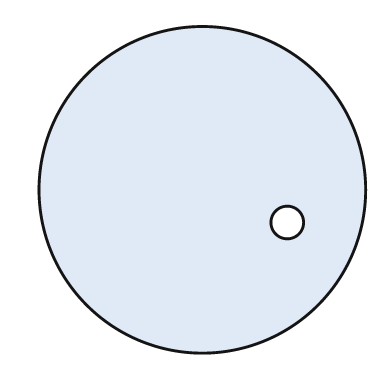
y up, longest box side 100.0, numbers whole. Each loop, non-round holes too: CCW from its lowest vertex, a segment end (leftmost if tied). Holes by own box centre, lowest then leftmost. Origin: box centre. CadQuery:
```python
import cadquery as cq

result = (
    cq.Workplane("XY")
    .moveTo(0.0, 0.0)
    .circle(50.0)
    .moveTo(26.0, -10.0)
    .circle(5.0)
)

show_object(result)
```